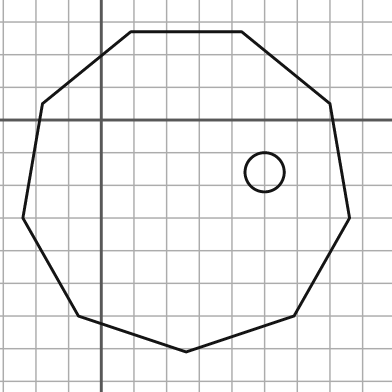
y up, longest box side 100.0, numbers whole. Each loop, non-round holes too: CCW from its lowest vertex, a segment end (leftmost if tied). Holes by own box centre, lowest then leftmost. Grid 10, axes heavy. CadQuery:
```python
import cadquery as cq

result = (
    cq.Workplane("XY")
    .moveTo(26.0, -71.0)
    .lineTo(59.0, -60.0)
    .lineTo(76.0, -30.0)
    .lineTo(70.0, 5.0)
    .lineTo(43.0, 27.0)
    .lineTo(9.0, 27.0)
    .lineTo(-18.0, 5.0)
    .lineTo(-24.0, -30.0)
    .lineTo(-7.0, -60.0)
    .close()
    .moveTo(50.0, -16.0)
    .circle(6.0)
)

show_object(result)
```